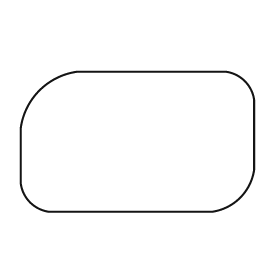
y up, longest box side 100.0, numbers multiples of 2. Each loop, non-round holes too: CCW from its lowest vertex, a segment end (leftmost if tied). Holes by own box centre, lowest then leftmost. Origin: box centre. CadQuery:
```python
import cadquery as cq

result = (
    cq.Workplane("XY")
    .moveTo(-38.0, -30.0)
    .lineTo(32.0, -30.0)
    .threePointArc((44.0, -24.0), (50.0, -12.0))
    .lineTo(50.0, 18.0)
    .threePointArc((46.0, 26.0), (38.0, 30.0))
    .lineTo(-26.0, 30.0)
    .threePointArc((-42.0, 22.0), (-50.0, 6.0))
    .lineTo(-50.0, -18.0)
    .threePointArc((-46.0, -26.0), (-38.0, -30.0))
    .close()
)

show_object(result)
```